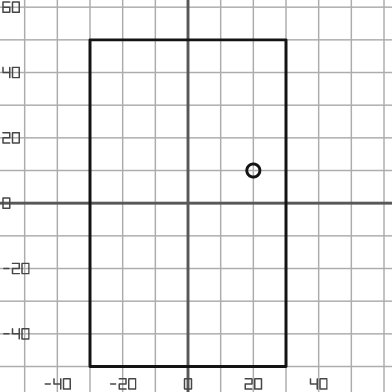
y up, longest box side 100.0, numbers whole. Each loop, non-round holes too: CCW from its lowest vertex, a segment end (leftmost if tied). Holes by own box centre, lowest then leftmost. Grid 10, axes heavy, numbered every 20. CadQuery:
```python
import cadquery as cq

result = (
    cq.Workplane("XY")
    .moveTo(-30.0, -50.0)
    .lineTo(30.0, -50.0)
    .lineTo(30.0, 50.0)
    .lineTo(-30.0, 50.0)
    .close()
    .moveTo(20.0, 10.0)
    .circle(2.0)
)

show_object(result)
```